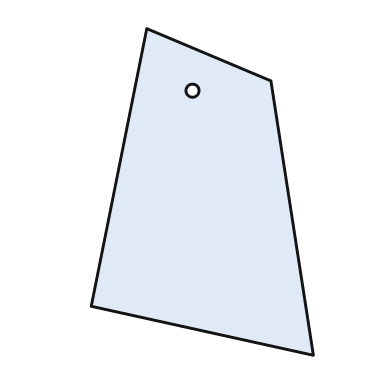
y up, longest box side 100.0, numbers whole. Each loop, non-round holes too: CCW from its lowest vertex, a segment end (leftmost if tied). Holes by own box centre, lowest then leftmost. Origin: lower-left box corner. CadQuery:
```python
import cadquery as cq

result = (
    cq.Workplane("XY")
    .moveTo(68.0, 0.0)
    .lineTo(55.0, 84.0)
    .lineTo(17.0, 100.0)
    .lineTo(0.0, 15.0)
    .close()
    .moveTo(31.0, 81.0)
    .circle(2.0)
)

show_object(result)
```